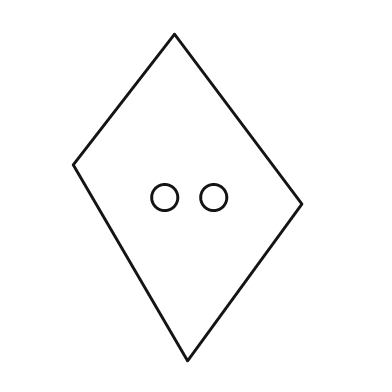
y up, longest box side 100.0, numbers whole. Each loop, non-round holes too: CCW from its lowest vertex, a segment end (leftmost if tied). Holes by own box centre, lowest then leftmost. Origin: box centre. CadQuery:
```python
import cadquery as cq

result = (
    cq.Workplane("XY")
    .moveTo(0.0, -50.0)
    .lineTo(35.0, -2.0)
    .lineTo(-4.0, 50.0)
    .lineTo(-35.0, 10.0)
    .close()
    .moveTo(-7.0, 0.0)
    .circle(4.0)
    .moveTo(8.0, 0.0)
    .circle(4.0)
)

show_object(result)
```